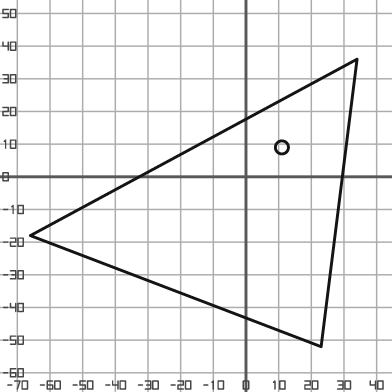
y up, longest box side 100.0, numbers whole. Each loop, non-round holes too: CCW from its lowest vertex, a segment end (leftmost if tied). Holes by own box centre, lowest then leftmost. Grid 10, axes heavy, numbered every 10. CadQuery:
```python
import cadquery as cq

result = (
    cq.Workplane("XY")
    .moveTo(23.0, -52.0)
    .lineTo(34.0, 36.0)
    .lineTo(-66.0, -18.0)
    .close()
    .moveTo(11.0, 9.0)
    .circle(2.0)
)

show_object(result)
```